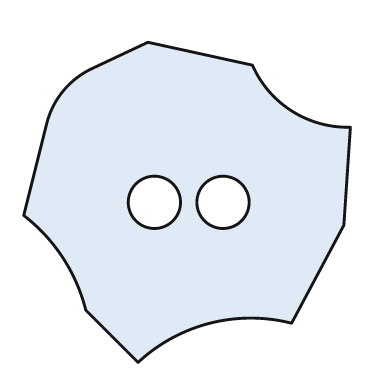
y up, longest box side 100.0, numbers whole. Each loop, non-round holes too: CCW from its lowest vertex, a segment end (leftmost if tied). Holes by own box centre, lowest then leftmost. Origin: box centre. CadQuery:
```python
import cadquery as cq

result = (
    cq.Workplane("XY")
    .moveTo(-15.0, -49.0)
    .threePointArc((7.0, -37.0), (32.0, -37.0))
    .lineTo(48.0, -7.0)
    .lineTo(50.0, 23.0)
    .threePointArc((32.0, 28.0), (20.0, 42.0))
    .lineTo(-12.0, 49.0)
    .lineTo(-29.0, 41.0)
    .threePointArc((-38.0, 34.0), (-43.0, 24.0))
    .lineTo(-50.0, -4.0)
    .threePointArc((-38.0, -17.0), (-31.0, -33.0))
    .close()
    .moveTo(-10.0, 0.0)
    .circle(8.0)
    .moveTo(11.0, 0.0)
    .circle(8.0)
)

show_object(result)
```